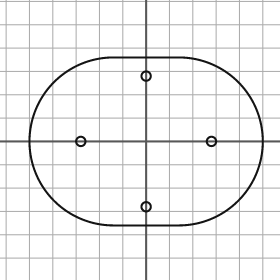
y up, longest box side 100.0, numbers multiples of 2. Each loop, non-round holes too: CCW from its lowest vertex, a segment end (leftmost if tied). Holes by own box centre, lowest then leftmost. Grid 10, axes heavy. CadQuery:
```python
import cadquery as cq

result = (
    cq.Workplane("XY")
    .moveTo(-14.0, -36.0)
    .lineTo(14.0, -36.0)
    .threePointArc((50.0, 0.0), (14.0, 36.0))
    .lineTo(-14.0, 36.0)
    .threePointArc((-50.0, 0.0), (-14.0, -36.0))
    .close()
    .moveTo(0.0, -28.0)
    .circle(2.0)
    .moveTo(-28.0, 0.0)
    .circle(2.0)
    .moveTo(28.0, 0.0)
    .circle(2.0)
    .moveTo(0.0, 28.0)
    .circle(2.0)
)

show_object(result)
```